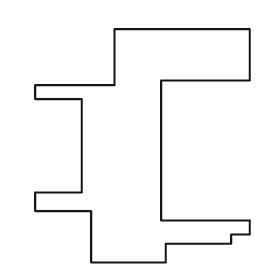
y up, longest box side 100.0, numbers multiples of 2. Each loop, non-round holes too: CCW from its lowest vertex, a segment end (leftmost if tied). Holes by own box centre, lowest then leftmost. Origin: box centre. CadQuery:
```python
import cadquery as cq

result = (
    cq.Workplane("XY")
    .moveTo(-22.0, -50.0)
    .lineTo(10.0, -50.0)
    .lineTo(10.0, -42.0)
    .lineTo(38.0, -42.0)
    .lineTo(38.0, -38.0)
    .lineTo(46.0, -38.0)
    .lineTo(46.0, -32.0)
    .lineTo(8.0, -32.0)
    .lineTo(8.0, 28.0)
    .lineTo(46.0, 28.0)
    .lineTo(46.0, 50.0)
    .lineTo(-12.0, 50.0)
    .lineTo(-12.0, 26.0)
    .lineTo(-46.0, 26.0)
    .lineTo(-46.0, 20.0)
    .lineTo(-26.0, 20.0)
    .lineTo(-26.0, -20.0)
    .lineTo(-46.0, -20.0)
    .lineTo(-46.0, -28.0)
    .lineTo(-22.0, -28.0)
    .close()
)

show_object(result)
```